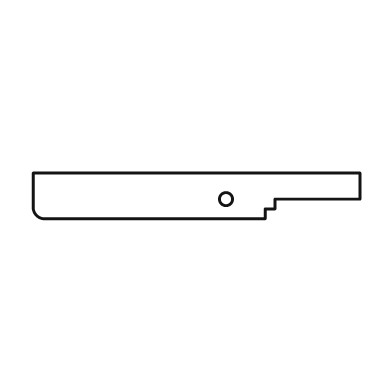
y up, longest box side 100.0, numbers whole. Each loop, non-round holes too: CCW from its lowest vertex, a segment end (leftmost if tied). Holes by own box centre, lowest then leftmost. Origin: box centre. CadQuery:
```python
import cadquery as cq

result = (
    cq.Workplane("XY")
    .moveTo(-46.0, -7.0)
    .lineTo(21.0, -7.0)
    .lineTo(21.0, -4.0)
    .lineTo(24.0, -4.0)
    .lineTo(24.0, -1.0)
    .lineTo(50.0, -1.0)
    .lineTo(50.0, 7.0)
    .lineTo(-50.0, 7.0)
    .lineTo(-50.0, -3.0)
    .threePointArc((-49.0, -6.0), (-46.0, -7.0))
    .close()
    .moveTo(9.0, -1.0)
    .circle(2.0)
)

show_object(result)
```